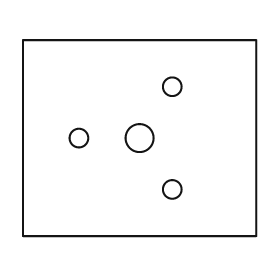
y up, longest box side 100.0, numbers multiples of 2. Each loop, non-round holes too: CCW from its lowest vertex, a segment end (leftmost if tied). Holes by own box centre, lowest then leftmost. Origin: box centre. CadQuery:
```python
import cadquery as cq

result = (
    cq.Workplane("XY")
    .moveTo(-50.0, -42.0)
    .lineTo(50.0, -42.0)
    .lineTo(50.0, 42.0)
    .lineTo(-50.0, 42.0)
    .close()
    .moveTo(14.0, -22.0)
    .circle(4.0)
    .moveTo(-26.0, 0.0)
    .circle(4.0)
    .moveTo(0.0, 0.0)
    .circle(6.0)
    .moveTo(14.0, 22.0)
    .circle(4.0)
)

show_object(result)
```